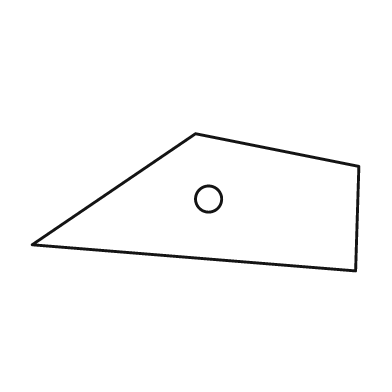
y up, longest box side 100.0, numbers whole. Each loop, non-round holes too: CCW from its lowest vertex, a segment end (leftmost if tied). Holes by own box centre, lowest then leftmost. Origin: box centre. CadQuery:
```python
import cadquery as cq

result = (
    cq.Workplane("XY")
    .moveTo(49.0, -21.0)
    .lineTo(50.0, 11.0)
    .lineTo(0.0, 21.0)
    .lineTo(-50.0, -13.0)
    .close()
    .moveTo(4.0, 1.0)
    .circle(4.0)
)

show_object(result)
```